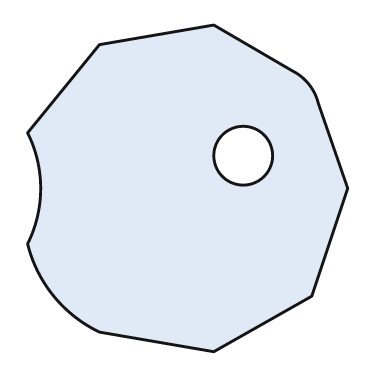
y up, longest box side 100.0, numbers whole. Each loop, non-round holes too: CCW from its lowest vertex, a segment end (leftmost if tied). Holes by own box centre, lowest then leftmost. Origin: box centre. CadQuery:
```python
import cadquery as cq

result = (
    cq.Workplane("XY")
    .moveTo(8.0, -50.0)
    .lineTo(38.0, -33.0)
    .lineTo(49.0, 0.0)
    .lineTo(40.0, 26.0)
    .threePointArc((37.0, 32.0), (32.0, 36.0))
    .lineTo(8.0, 50.0)
    .lineTo(-27.0, 44.0)
    .lineTo(-49.0, 17.0)
    .threePointArc((-45.0, 0.0), (-49.0, -17.0))
    .threePointArc((-41.0, -33.0), (-27.0, -44.0))
    .close()
    .moveTo(17.0, 10.0)
    .circle(9.0)
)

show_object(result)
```